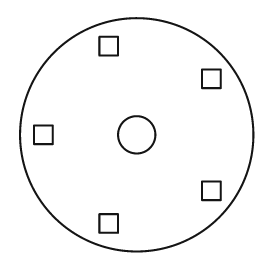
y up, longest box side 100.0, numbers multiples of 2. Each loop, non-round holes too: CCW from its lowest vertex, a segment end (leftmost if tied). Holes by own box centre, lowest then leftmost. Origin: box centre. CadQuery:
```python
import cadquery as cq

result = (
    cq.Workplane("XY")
    .moveTo(0.0, 0.0)
    .circle(50.0)
    .moveTo(-16.0, -42.0)
    .lineTo(-8.0, -42.0)
    .lineTo(-8.0, -34.0)
    .lineTo(-16.0, -34.0)
    .close()
    .moveTo(28.0, -28.0)
    .lineTo(36.0, -28.0)
    .lineTo(36.0, -20.0)
    .lineTo(28.0, -20.0)
    .close()
    .moveTo(-44.0, -4.0)
    .lineTo(-36.0, -4.0)
    .lineTo(-36.0, 4.0)
    .lineTo(-44.0, 4.0)
    .close()
    .moveTo(0.0, 0.0)
    .circle(8.0)
    .moveTo(28.0, 20.0)
    .lineTo(36.0, 20.0)
    .lineTo(36.0, 28.0)
    .lineTo(28.0, 28.0)
    .close()
    .moveTo(-16.0, 34.0)
    .lineTo(-8.0, 34.0)
    .lineTo(-8.0, 42.0)
    .lineTo(-16.0, 42.0)
    .close()
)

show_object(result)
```